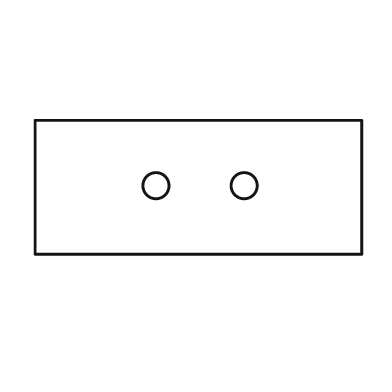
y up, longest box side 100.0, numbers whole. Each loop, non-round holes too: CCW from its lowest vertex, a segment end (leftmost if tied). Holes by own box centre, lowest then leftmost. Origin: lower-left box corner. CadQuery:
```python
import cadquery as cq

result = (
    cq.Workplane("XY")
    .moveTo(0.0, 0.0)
    .lineTo(100.0, 0.0)
    .lineTo(100.0, 41.0)
    .lineTo(0.0, 41.0)
    .close()
    .moveTo(37.0, 21.0)
    .circle(4.0)
    .moveTo(64.0, 21.0)
    .circle(4.0)
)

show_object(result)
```